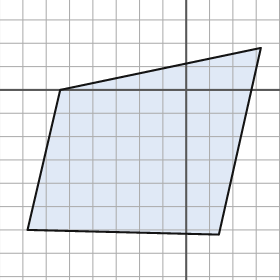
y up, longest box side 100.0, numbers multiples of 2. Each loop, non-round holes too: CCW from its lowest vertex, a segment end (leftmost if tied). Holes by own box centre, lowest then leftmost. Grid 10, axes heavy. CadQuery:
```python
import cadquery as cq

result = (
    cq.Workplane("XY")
    .moveTo(14.0, -62.0)
    .lineTo(32.0, 18.0)
    .lineTo(-54.0, 0.0)
    .lineTo(-68.0, -60.0)
    .close()
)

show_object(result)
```